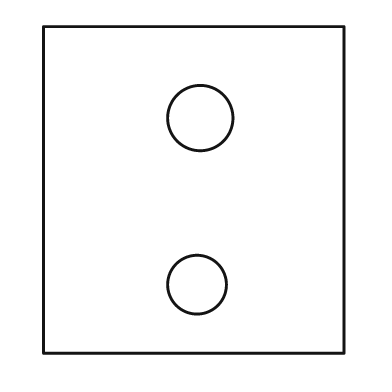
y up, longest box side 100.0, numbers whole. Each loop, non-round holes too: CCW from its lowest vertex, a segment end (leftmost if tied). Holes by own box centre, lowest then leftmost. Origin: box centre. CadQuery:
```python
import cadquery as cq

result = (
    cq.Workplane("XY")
    .moveTo(-46.0, -50.0)
    .lineTo(46.0, -50.0)
    .lineTo(46.0, 50.0)
    .lineTo(-46.0, 50.0)
    .close()
    .moveTo(1.0, -29.0)
    .circle(9.0)
    .moveTo(2.0, 22.0)
    .circle(10.0)
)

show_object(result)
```